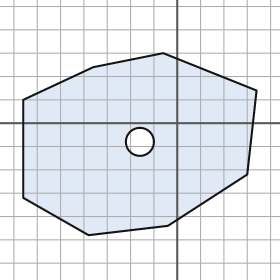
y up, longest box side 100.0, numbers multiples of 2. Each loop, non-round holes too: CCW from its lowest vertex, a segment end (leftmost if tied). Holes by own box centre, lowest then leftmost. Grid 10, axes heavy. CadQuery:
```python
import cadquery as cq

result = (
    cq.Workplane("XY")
    .moveTo(-38.0, -48.0)
    .lineTo(-4.0, -44.0)
    .lineTo(30.0, -22.0)
    .lineTo(34.0, 14.0)
    .lineTo(-6.0, 30.0)
    .lineTo(-36.0, 24.0)
    .lineTo(-66.0, 10.0)
    .lineTo(-66.0, -32.0)
    .close()
    .moveTo(-16.0, -8.0)
    .circle(6.0)
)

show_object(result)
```